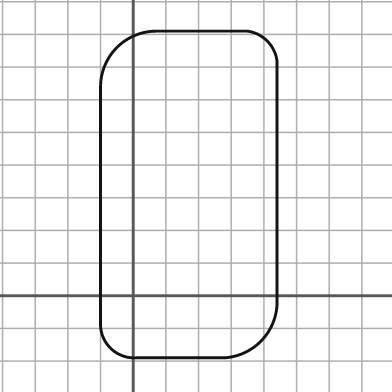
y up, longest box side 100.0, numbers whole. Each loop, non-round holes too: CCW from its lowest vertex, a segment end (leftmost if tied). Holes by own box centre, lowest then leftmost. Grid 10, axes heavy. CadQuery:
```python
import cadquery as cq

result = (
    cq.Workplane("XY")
    .moveTo(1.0, -19.0)
    .lineTo(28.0, -19.0)
    .threePointArc((39.0, -14.0), (44.0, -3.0))
    .lineTo(44.0, 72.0)
    .threePointArc((41.0, 78.0), (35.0, 81.0))
    .lineTo(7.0, 81.0)
    .threePointArc((-5.0, 76.0), (-10.0, 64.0))
    .lineTo(-10.0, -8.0)
    .threePointArc((-7.0, -16.0), (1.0, -19.0))
    .close()
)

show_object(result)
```